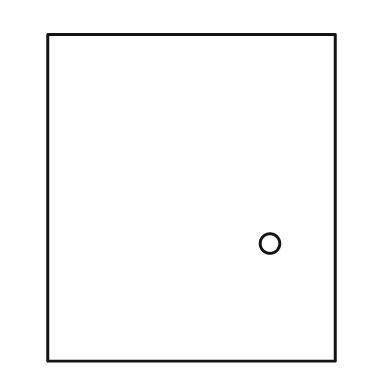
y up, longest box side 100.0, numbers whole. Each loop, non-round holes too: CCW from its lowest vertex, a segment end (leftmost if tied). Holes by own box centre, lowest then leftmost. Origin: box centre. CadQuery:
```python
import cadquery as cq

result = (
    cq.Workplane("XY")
    .moveTo(-44.0, -50.0)
    .lineTo(44.0, -50.0)
    .lineTo(44.0, 50.0)
    .lineTo(-44.0, 50.0)
    .close()
    .moveTo(24.0, -14.0)
    .circle(3.0)
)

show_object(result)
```